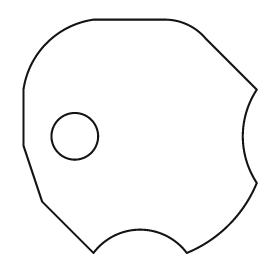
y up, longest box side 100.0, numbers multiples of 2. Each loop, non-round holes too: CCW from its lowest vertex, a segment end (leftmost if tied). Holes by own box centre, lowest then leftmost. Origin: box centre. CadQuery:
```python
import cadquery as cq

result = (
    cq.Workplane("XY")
    .moveTo(-20.0, -50.0)
    .threePointArc((0.0, -40.0), (20.0, -50.0))
    .threePointArc((38.0, -38.0), (50.0, -20.0))
    .threePointArc((44.0, 0.0), (50.0, 20.0))
    .lineTo(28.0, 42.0)
    .threePointArc((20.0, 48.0), (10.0, 50.0))
    .lineTo(-20.0, 50.0)
    .threePointArc((-40.0, 40.0), (-50.0, 20.0))
    .lineTo(-50.0, -4.0)
    .lineTo(-42.0, -28.0)
    .close()
    .moveTo(-28.0, 0.0)
    .circle(10.0)
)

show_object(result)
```